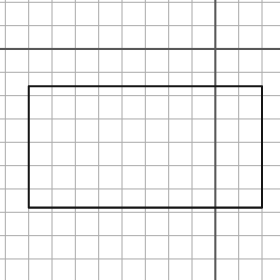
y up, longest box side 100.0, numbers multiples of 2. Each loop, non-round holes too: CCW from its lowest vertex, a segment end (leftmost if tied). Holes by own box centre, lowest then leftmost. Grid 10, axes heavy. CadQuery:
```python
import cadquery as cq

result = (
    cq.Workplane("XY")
    .moveTo(-80.0, -68.0)
    .lineTo(20.0, -68.0)
    .lineTo(20.0, -16.0)
    .lineTo(-80.0, -16.0)
    .close()
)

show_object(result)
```